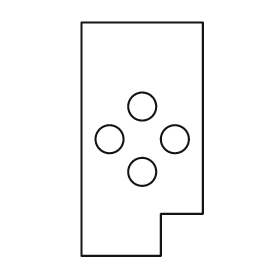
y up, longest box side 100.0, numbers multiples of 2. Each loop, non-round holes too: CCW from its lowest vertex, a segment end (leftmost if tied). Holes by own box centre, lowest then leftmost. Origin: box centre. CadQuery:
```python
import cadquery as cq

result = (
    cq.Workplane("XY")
    .moveTo(-26.0, -50.0)
    .lineTo(8.0, -50.0)
    .lineTo(8.0, -32.0)
    .lineTo(26.0, -32.0)
    .lineTo(26.0, 50.0)
    .lineTo(-26.0, 50.0)
    .close()
    .moveTo(0.0, -14.0)
    .circle(6.0)
    .moveTo(-14.0, 0.0)
    .circle(6.0)
    .moveTo(14.0, 0.0)
    .circle(6.0)
    .moveTo(0.0, 14.0)
    .circle(6.0)
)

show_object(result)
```